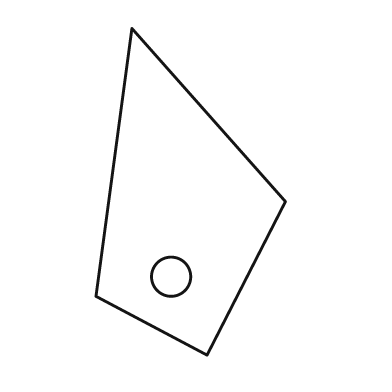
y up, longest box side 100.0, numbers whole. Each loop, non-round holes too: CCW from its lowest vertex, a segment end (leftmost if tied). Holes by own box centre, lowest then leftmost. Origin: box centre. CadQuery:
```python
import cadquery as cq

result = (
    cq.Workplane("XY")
    .moveTo(5.0, -50.0)
    .lineTo(29.0, -3.0)
    .lineTo(-18.0, 50.0)
    .lineTo(-29.0, -32.0)
    .close()
    .moveTo(-6.0, -26.0)
    .circle(6.0)
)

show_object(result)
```